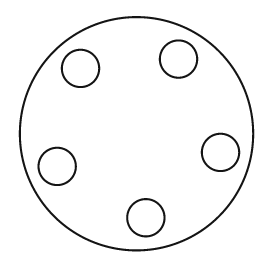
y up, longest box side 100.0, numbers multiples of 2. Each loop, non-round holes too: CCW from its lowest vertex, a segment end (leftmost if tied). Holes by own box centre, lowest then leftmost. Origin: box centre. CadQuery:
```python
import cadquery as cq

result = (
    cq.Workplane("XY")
    .moveTo(0.0, 0.0)
    .circle(50.0)
    .moveTo(4.0, -36.0)
    .circle(8.0)
    .moveTo(-34.0, -14.0)
    .circle(8.0)
    .moveTo(36.0, -8.0)
    .circle(8.0)
    .moveTo(-24.0, 28.0)
    .circle(8.0)
    .moveTo(18.0, 32.0)
    .circle(8.0)
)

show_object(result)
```